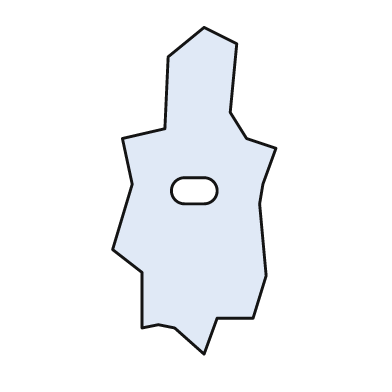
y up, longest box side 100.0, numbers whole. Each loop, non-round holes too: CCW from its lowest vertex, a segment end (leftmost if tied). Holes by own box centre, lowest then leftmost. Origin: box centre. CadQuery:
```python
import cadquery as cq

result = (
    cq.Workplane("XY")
    .moveTo(3.0, -50.0)
    .lineTo(7.0, -39.0)
    .lineTo(18.0, -39.0)
    .lineTo(22.0, -26.0)
    .lineTo(20.0, -4.0)
    .lineTo(21.0, 2.0)
    .lineTo(25.0, 13.0)
    .lineTo(16.0, 16.0)
    .lineTo(11.0, 24.0)
    .lineTo(13.0, 45.0)
    .lineTo(3.0, 50.0)
    .lineTo(-8.0, 41.0)
    .lineTo(-9.0, 19.0)
    .lineTo(-22.0, 16.0)
    .lineTo(-19.0, 2.0)
    .lineTo(-25.0, -18.0)
    .lineTo(-16.0, -25.0)
    .lineTo(-16.0, -42.0)
    .lineTo(-11.0, -41.0)
    .lineTo(-6.0, -42.0)
    .close()
    .moveTo(-3.0, -4.0)
    .lineTo(3.0, -4.0)
    .threePointArc((7.0, 0.0), (3.0, 4.0))
    .lineTo(-3.0, 4.0)
    .threePointArc((-7.0, 0.0), (-3.0, -4.0))
    .close()
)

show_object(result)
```